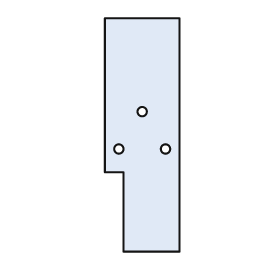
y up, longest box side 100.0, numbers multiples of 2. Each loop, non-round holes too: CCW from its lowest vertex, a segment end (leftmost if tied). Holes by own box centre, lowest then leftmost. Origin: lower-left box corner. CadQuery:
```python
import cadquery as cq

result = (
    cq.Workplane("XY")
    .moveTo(8.0, 0.0)
    .lineTo(32.0, 0.0)
    .lineTo(32.0, 100.0)
    .lineTo(0.0, 100.0)
    .lineTo(0.0, 34.0)
    .lineTo(8.0, 34.0)
    .close()
    .moveTo(6.0, 44.0)
    .circle(2.0)
    .moveTo(26.0, 44.0)
    .circle(2.0)
    .moveTo(16.0, 60.0)
    .circle(2.0)
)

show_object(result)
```